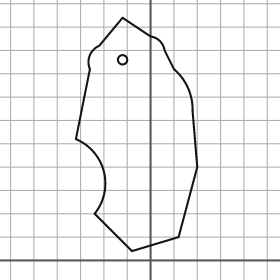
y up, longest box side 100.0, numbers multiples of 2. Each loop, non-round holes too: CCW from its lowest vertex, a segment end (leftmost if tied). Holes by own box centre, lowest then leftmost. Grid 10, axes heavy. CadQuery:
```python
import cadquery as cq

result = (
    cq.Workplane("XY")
    .moveTo(-8.0, 4.0)
    .lineTo(12.0, 10.0)
    .lineTo(20.0, 40.0)
    .lineTo(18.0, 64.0)
    .threePointArc((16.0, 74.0), (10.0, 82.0))
    .lineTo(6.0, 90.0)
    .threePointArc((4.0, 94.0), (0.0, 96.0))
    .lineTo(-12.0, 104.0)
    .lineTo(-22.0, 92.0)
    .threePointArc((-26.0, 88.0), (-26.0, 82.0))
    .lineTo(-32.0, 52.0)
    .threePointArc((-20.0, 38.0), (-24.0, 20.0))
    .close()
    .moveTo(-12.0, 86.0)
    .circle(2.0)
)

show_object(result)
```